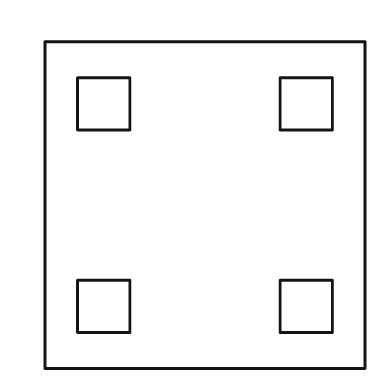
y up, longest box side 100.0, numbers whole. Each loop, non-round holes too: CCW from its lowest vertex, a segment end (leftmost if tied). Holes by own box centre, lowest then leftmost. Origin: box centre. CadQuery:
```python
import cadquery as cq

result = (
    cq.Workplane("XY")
    .moveTo(-49.0, -50.0)
    .lineTo(49.0, -50.0)
    .lineTo(49.0, 50.0)
    .lineTo(-49.0, 50.0)
    .close()
    .moveTo(-39.0, -39.0)
    .lineTo(-23.0, -39.0)
    .lineTo(-23.0, -23.0)
    .lineTo(-39.0, -23.0)
    .close()
    .moveTo(23.0, -39.0)
    .lineTo(39.0, -39.0)
    .lineTo(39.0, -23.0)
    .lineTo(23.0, -23.0)
    .close()
    .moveTo(-39.0, 23.0)
    .lineTo(-23.0, 23.0)
    .lineTo(-23.0, 39.0)
    .lineTo(-39.0, 39.0)
    .close()
    .moveTo(23.0, 23.0)
    .lineTo(39.0, 23.0)
    .lineTo(39.0, 39.0)
    .lineTo(23.0, 39.0)
    .close()
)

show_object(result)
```